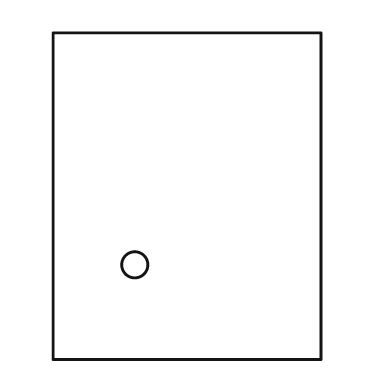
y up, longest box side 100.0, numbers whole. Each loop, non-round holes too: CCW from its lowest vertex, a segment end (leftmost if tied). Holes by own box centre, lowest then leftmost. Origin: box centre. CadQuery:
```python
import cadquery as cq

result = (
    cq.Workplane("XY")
    .moveTo(-41.0, -50.0)
    .lineTo(41.0, -50.0)
    .lineTo(41.0, 50.0)
    .lineTo(-41.0, 50.0)
    .close()
    .moveTo(-16.0, -21.0)
    .circle(4.0)
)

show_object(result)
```